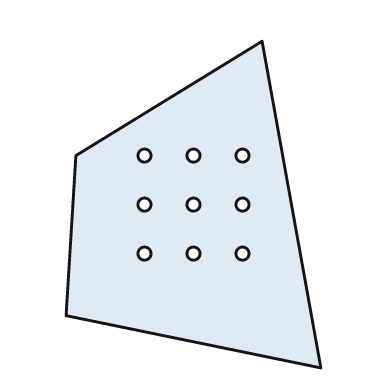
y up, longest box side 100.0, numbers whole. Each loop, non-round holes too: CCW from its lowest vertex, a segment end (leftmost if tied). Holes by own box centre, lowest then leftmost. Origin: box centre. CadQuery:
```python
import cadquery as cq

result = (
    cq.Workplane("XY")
    .moveTo(39.0, -50.0)
    .lineTo(21.0, 50.0)
    .lineTo(-36.0, 15.0)
    .lineTo(-39.0, -34.0)
    .close()
    .moveTo(-15.0, -15.0)
    .circle(2.0)
    .moveTo(0.0, -15.0)
    .circle(2.0)
    .moveTo(15.0, -15.0)
    .circle(2.0)
    .moveTo(-15.0, 0.0)
    .circle(2.0)
    .moveTo(0.0, 0.0)
    .circle(2.0)
    .moveTo(15.0, 0.0)
    .circle(2.0)
    .moveTo(-15.0, 15.0)
    .circle(2.0)
    .moveTo(0.0, 15.0)
    .circle(2.0)
    .moveTo(15.0, 15.0)
    .circle(2.0)
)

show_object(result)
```